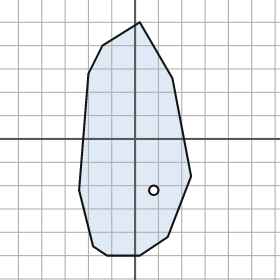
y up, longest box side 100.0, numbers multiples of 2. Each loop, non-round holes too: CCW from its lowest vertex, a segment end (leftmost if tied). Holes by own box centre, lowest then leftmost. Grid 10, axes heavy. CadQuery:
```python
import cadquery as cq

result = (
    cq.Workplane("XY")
    .moveTo(-12.0, -50.0)
    .lineTo(2.0, -50.0)
    .lineTo(14.0, -42.0)
    .lineTo(24.0, -16.0)
    .lineTo(16.0, 26.0)
    .lineTo(2.0, 50.0)
    .lineTo(-14.0, 40.0)
    .lineTo(-20.0, 28.0)
    .lineTo(-24.0, -22.0)
    .lineTo(-18.0, -46.0)
    .close()
    .moveTo(8.0, -22.0)
    .circle(2.0)
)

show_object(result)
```